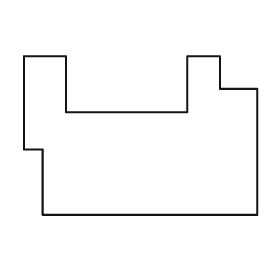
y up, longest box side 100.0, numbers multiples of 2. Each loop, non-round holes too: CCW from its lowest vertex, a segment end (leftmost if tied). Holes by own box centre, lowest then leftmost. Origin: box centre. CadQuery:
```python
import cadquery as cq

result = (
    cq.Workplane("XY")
    .moveTo(-42.0, -34.0)
    .lineTo(50.0, -34.0)
    .lineTo(50.0, 20.0)
    .lineTo(34.0, 20.0)
    .lineTo(34.0, 34.0)
    .lineTo(20.0, 34.0)
    .lineTo(20.0, 10.0)
    .lineTo(-32.0, 10.0)
    .lineTo(-32.0, 34.0)
    .lineTo(-50.0, 34.0)
    .lineTo(-50.0, -6.0)
    .lineTo(-42.0, -6.0)
    .close()
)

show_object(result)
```